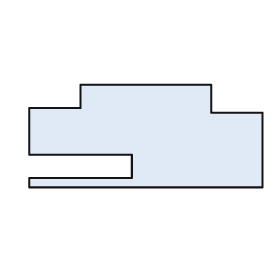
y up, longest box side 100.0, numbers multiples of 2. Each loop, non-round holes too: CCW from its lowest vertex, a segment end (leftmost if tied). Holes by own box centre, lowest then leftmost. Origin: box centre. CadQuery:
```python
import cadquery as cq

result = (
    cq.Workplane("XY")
    .moveTo(-50.0, -22.0)
    .lineTo(50.0, -22.0)
    .lineTo(50.0, 10.0)
    .lineTo(28.0, 10.0)
    .lineTo(28.0, 22.0)
    .lineTo(-28.0, 22.0)
    .lineTo(-28.0, 12.0)
    .lineTo(-50.0, 12.0)
    .lineTo(-50.0, -8.0)
    .lineTo(-6.0, -8.0)
    .lineTo(-6.0, -18.0)
    .lineTo(-50.0, -18.0)
    .close()
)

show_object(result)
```